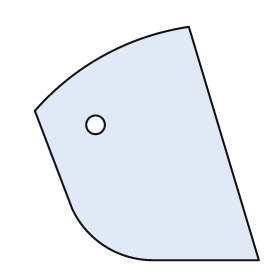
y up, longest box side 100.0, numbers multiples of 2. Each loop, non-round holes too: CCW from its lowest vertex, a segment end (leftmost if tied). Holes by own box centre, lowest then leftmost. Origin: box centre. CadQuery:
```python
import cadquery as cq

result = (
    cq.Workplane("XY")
    .moveTo(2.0, -50.0)
    .lineTo(48.0, -50.0)
    .lineTo(18.0, 50.0)
    .threePointArc((-18.0, 38.0), (-48.0, 14.0))
    .lineTo(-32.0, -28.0)
    .threePointArc((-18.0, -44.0), (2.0, -50.0))
    .close()
    .moveTo(-22.0, 8.0)
    .circle(4.0)
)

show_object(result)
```